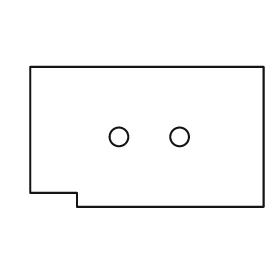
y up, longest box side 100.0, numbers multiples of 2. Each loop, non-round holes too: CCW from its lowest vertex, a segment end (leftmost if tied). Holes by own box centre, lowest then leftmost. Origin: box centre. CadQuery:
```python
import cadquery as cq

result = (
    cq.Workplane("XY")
    .moveTo(-30.0, -30.0)
    .lineTo(50.0, -30.0)
    .lineTo(50.0, 30.0)
    .lineTo(-50.0, 30.0)
    .lineTo(-50.0, -24.0)
    .lineTo(-30.0, -24.0)
    .close()
    .moveTo(-12.0, 0.0)
    .circle(4.0)
    .moveTo(14.0, 0.0)
    .circle(4.0)
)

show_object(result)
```